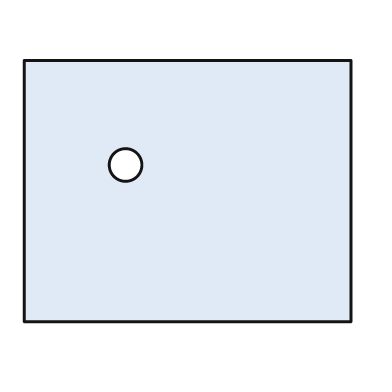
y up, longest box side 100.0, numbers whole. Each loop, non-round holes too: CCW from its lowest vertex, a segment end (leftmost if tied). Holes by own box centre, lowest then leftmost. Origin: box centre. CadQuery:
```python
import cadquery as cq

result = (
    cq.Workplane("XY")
    .moveTo(-50.0, -40.0)
    .lineTo(50.0, -40.0)
    .lineTo(50.0, 40.0)
    .lineTo(-50.0, 40.0)
    .close()
    .moveTo(-19.0, 8.0)
    .circle(5.0)
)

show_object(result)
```